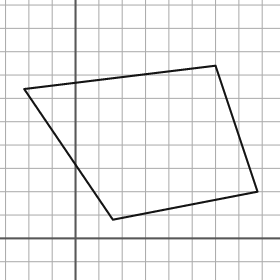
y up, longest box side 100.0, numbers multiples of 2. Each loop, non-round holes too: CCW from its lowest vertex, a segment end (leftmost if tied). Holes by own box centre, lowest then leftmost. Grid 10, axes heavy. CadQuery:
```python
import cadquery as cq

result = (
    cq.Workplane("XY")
    .moveTo(16.0, 8.0)
    .lineTo(78.0, 20.0)
    .lineTo(60.0, 74.0)
    .lineTo(-22.0, 64.0)
    .close()
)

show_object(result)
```